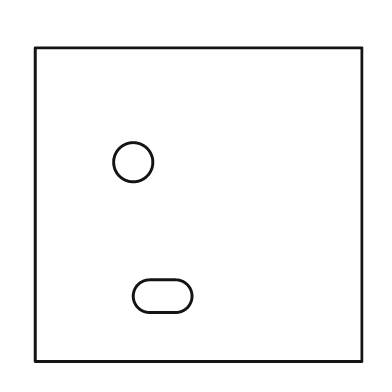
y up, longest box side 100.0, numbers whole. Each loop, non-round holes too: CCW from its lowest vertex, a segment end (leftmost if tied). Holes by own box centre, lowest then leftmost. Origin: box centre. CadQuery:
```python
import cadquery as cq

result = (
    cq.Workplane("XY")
    .moveTo(-50.0, -48.0)
    .lineTo(50.0, -48.0)
    .lineTo(50.0, 48.0)
    .lineTo(-50.0, 48.0)
    .close()
    .moveTo(-15.0, -33.0)
    .lineTo(-7.0, -33.0)
    .threePointArc((-2.0, -28.0), (-7.0, -23.0))
    .lineTo(-15.0, -23.0)
    .threePointArc((-20.0, -28.0), (-15.0, -33.0))
    .close()
    .moveTo(-20.0, 13.0)
    .circle(6.0)
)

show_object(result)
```